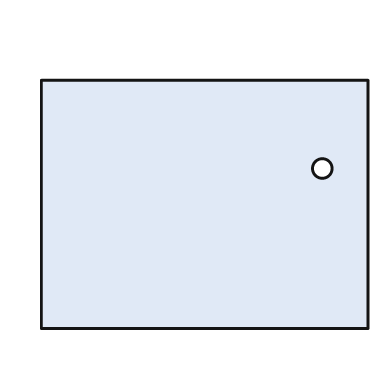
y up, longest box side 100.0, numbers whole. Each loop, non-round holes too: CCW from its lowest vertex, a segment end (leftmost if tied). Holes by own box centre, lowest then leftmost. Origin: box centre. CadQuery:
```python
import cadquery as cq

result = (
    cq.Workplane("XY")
    .moveTo(-50.0, -38.0)
    .lineTo(50.0, -38.0)
    .lineTo(50.0, 38.0)
    .lineTo(-50.0, 38.0)
    .close()
    .moveTo(36.0, 11.0)
    .circle(3.0)
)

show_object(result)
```